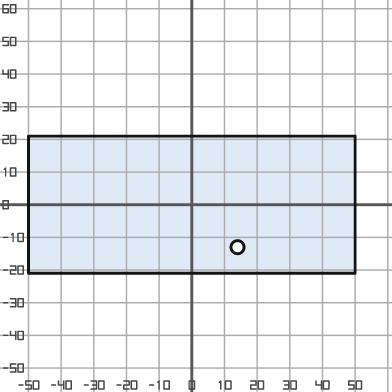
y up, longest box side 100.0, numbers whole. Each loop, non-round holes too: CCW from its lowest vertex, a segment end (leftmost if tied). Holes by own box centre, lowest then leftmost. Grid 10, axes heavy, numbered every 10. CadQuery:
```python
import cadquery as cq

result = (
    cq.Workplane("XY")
    .moveTo(-50.0, -21.0)
    .lineTo(50.0, -21.0)
    .lineTo(50.0, 21.0)
    .lineTo(-50.0, 21.0)
    .close()
    .moveTo(14.0, -13.0)
    .circle(2.0)
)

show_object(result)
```